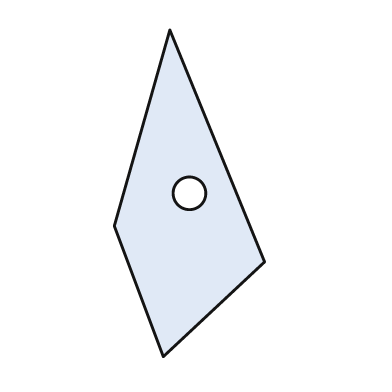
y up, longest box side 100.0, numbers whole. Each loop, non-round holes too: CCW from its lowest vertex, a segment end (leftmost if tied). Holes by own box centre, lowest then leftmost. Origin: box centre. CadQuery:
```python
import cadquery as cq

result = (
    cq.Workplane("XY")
    .moveTo(-8.0, -50.0)
    .lineTo(23.0, -21.0)
    .lineTo(-6.0, 50.0)
    .lineTo(-23.0, -10.0)
    .close()
    .moveTo(0.0, 0.0)
    .circle(5.0)
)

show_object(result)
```